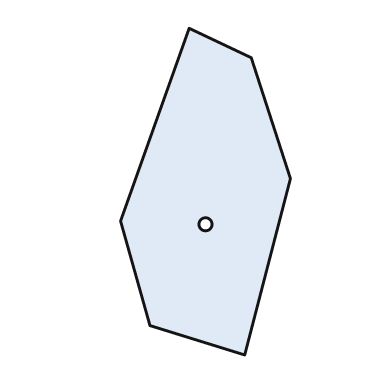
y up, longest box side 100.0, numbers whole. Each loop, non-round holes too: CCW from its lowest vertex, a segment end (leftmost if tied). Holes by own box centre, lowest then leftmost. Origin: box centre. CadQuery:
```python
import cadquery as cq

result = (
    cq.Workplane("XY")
    .moveTo(12.0, -50.0)
    .lineTo(26.0, 4.0)
    .lineTo(14.0, 41.0)
    .lineTo(-5.0, 50.0)
    .lineTo(-26.0, -9.0)
    .lineTo(-17.0, -41.0)
    .close()
    .moveTo(0.0, -10.0)
    .circle(2.0)
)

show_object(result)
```